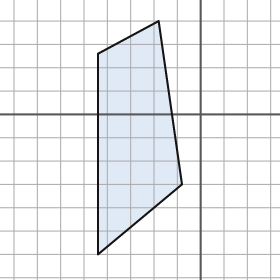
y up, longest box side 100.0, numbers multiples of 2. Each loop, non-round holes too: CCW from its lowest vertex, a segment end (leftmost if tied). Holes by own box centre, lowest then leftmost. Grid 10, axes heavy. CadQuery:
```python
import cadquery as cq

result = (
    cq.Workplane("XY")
    .moveTo(-44.0, -60.0)
    .lineTo(-8.0, -30.0)
    .lineTo(-18.0, 40.0)
    .lineTo(-44.0, 26.0)
    .close()
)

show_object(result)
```